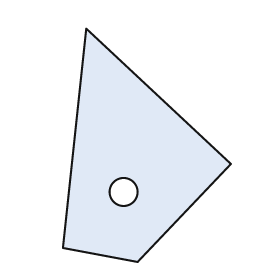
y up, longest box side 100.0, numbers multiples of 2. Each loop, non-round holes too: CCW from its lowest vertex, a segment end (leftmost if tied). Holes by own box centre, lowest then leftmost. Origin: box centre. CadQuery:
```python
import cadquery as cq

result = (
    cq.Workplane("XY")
    .moveTo(-4.0, -50.0)
    .lineTo(36.0, -8.0)
    .lineTo(-26.0, 50.0)
    .lineTo(-36.0, -44.0)
    .close()
    .moveTo(-10.0, -20.0)
    .circle(6.0)
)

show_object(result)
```